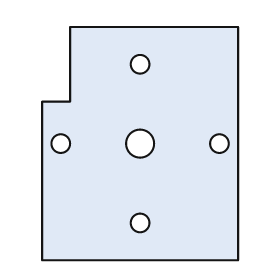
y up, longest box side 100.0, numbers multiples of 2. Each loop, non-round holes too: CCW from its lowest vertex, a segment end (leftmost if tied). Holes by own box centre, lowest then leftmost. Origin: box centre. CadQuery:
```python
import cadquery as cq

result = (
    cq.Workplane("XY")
    .moveTo(-42.0, -50.0)
    .lineTo(42.0, -50.0)
    .lineTo(42.0, 50.0)
    .lineTo(-30.0, 50.0)
    .lineTo(-30.0, 18.0)
    .lineTo(-42.0, 18.0)
    .close()
    .moveTo(0.0, -34.0)
    .circle(4.0)
    .moveTo(-34.0, 0.0)
    .circle(4.0)
    .moveTo(0.0, 0.0)
    .circle(6.0)
    .moveTo(34.0, 0.0)
    .circle(4.0)
    .moveTo(0.0, 34.0)
    .circle(4.0)
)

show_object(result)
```